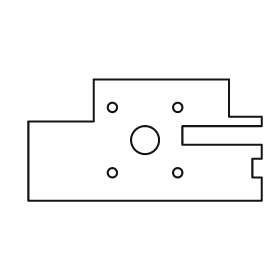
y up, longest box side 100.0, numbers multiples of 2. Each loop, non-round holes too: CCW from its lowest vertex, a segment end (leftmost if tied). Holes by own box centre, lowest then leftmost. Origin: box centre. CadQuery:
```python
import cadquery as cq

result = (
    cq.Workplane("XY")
    .moveTo(-50.0, -26.0)
    .lineTo(50.0, -26.0)
    .lineTo(50.0, -16.0)
    .lineTo(46.0, -16.0)
    .lineTo(46.0, -8.0)
    .lineTo(50.0, -8.0)
    .lineTo(50.0, -2.0)
    .lineTo(16.0, -2.0)
    .lineTo(16.0, 6.0)
    .lineTo(50.0, 6.0)
    .lineTo(50.0, 10.0)
    .lineTo(36.0, 10.0)
    .lineTo(36.0, 26.0)
    .lineTo(-22.0, 26.0)
    .lineTo(-22.0, 8.0)
    .lineTo(-50.0, 8.0)
    .close()
    .moveTo(-14.0, -14.0)
    .circle(2.0)
    .moveTo(14.0, -14.0)
    .circle(2.0)
    .moveTo(0.0, 0.0)
    .circle(6.0)
    .moveTo(-14.0, 14.0)
    .circle(2.0)
    .moveTo(14.0, 14.0)
    .circle(2.0)
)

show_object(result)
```